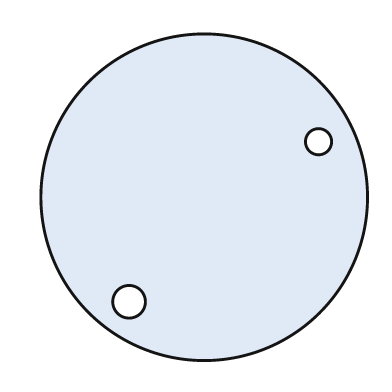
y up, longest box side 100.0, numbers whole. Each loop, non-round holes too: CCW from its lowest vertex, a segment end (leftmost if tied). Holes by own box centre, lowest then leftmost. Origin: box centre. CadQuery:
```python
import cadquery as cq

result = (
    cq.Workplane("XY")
    .moveTo(0.0, 0.0)
    .circle(50.0)
    .moveTo(-23.0, -32.0)
    .circle(5.0)
    .moveTo(35.0, 17.0)
    .circle(4.0)
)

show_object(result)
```